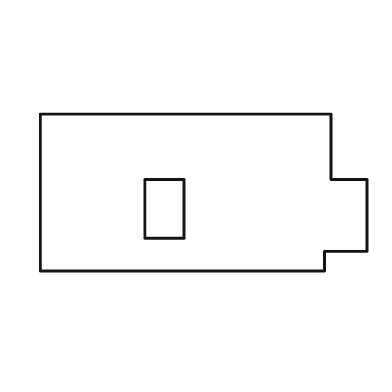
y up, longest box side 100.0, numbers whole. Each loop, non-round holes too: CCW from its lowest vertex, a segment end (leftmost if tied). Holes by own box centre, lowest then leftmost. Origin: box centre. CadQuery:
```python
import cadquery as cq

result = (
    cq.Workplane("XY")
    .moveTo(-50.0, -24.0)
    .lineTo(37.0, -24.0)
    .lineTo(37.0, -18.0)
    .lineTo(50.0, -18.0)
    .lineTo(50.0, 4.0)
    .lineTo(39.0, 4.0)
    .lineTo(39.0, 24.0)
    .lineTo(-50.0, 24.0)
    .close()
    .moveTo(-18.0, -14.0)
    .lineTo(-6.0, -14.0)
    .lineTo(-6.0, 4.0)
    .lineTo(-18.0, 4.0)
    .close()
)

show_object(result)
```